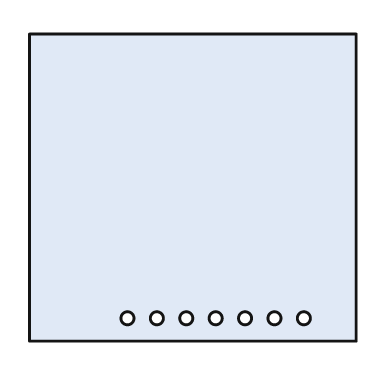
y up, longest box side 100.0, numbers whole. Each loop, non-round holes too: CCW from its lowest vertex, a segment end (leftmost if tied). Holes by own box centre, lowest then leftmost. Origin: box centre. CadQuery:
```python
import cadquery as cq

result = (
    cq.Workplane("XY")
    .moveTo(-50.0, -47.0)
    .lineTo(50.0, -47.0)
    .lineTo(50.0, 47.0)
    .lineTo(-50.0, 47.0)
    .close()
    .moveTo(-20.0, -40.0)
    .circle(2.0)
    .moveTo(-11.0, -40.0)
    .circle(2.0)
    .moveTo(-2.0, -40.0)
    .circle(2.0)
    .moveTo(7.0, -40.0)
    .circle(2.0)
    .moveTo(16.0, -40.0)
    .circle(2.0)
    .moveTo(25.0, -40.0)
    .circle(2.0)
    .moveTo(34.0, -40.0)
    .circle(2.0)
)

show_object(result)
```